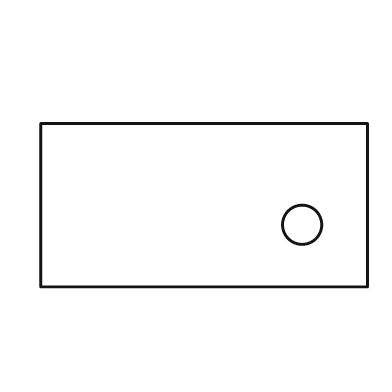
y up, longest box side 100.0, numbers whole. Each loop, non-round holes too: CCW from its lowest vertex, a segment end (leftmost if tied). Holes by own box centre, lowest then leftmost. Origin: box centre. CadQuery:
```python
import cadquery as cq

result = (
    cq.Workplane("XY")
    .moveTo(-50.0, -25.0)
    .lineTo(50.0, -25.0)
    .lineTo(50.0, 25.0)
    .lineTo(-50.0, 25.0)
    .close()
    .moveTo(30.0, -6.0)
    .circle(6.0)
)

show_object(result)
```